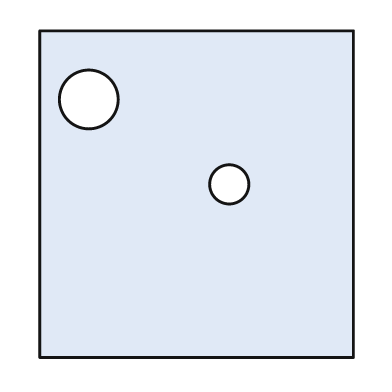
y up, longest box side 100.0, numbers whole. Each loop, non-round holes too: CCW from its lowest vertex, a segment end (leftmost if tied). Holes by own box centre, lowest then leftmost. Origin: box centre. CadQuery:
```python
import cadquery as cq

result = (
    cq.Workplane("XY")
    .moveTo(-48.0, -50.0)
    .lineTo(48.0, -50.0)
    .lineTo(48.0, 50.0)
    .lineTo(-48.0, 50.0)
    .close()
    .moveTo(10.0, 3.0)
    .circle(6.0)
    .moveTo(-33.0, 29.0)
    .circle(9.0)
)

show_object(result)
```